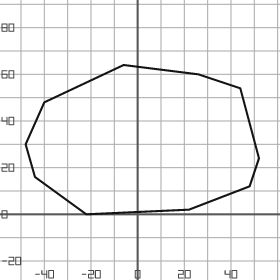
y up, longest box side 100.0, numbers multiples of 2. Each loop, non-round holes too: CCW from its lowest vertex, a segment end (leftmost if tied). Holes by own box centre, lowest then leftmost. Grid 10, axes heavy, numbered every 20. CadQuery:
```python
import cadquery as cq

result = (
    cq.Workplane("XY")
    .moveTo(-22.0, 0.0)
    .lineTo(22.0, 2.0)
    .lineTo(48.0, 12.0)
    .lineTo(52.0, 24.0)
    .lineTo(44.0, 54.0)
    .lineTo(26.0, 60.0)
    .lineTo(-6.0, 64.0)
    .lineTo(-40.0, 48.0)
    .lineTo(-48.0, 30.0)
    .lineTo(-44.0, 16.0)
    .close()
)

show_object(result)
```